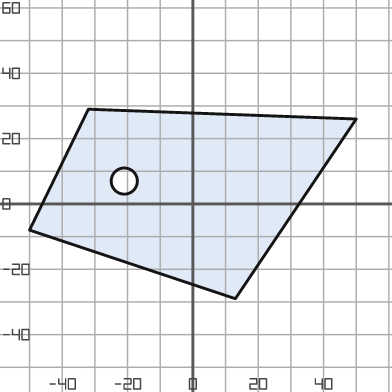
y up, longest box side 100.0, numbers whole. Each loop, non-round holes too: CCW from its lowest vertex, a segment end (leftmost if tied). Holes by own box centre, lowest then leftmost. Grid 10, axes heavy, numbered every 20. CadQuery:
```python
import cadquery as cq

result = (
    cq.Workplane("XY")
    .moveTo(13.0, -29.0)
    .lineTo(50.0, 26.0)
    .lineTo(-32.0, 29.0)
    .lineTo(-50.0, -8.0)
    .close()
    .moveTo(-21.0, 7.0)
    .circle(4.0)
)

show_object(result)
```